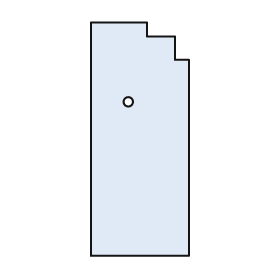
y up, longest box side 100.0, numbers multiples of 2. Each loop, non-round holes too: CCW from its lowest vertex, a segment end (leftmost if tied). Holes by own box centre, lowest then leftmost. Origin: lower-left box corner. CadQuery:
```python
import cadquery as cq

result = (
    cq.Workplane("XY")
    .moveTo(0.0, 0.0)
    .lineTo(42.0, 0.0)
    .lineTo(42.0, 84.0)
    .lineTo(36.0, 84.0)
    .lineTo(36.0, 94.0)
    .lineTo(24.0, 94.0)
    .lineTo(24.0, 100.0)
    .lineTo(0.0, 100.0)
    .close()
    .moveTo(16.0, 66.0)
    .circle(2.0)
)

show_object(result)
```